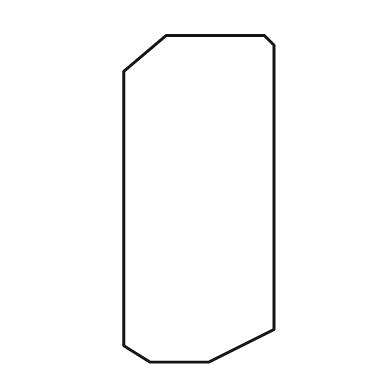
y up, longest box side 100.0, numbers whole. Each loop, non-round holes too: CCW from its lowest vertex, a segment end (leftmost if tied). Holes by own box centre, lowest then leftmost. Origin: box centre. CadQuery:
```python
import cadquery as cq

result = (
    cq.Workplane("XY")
    .moveTo(-15.0, -50.0)
    .lineTo(3.0, -50.0)
    .lineTo(23.0, -40.0)
    .lineTo(23.0, 47.0)
    .lineTo(20.0, 50.0)
    .lineTo(-10.0, 50.0)
    .lineTo(-23.0, 39.0)
    .lineTo(-23.0, -45.0)
    .close()
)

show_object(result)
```